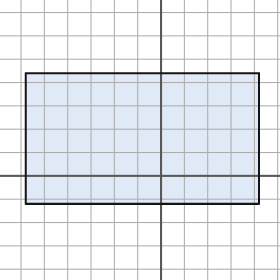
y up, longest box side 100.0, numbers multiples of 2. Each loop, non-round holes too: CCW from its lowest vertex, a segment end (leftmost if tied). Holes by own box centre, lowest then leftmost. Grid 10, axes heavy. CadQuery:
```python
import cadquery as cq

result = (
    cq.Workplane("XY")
    .moveTo(-58.0, -12.0)
    .lineTo(42.0, -12.0)
    .lineTo(42.0, 44.0)
    .lineTo(-58.0, 44.0)
    .close()
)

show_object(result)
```